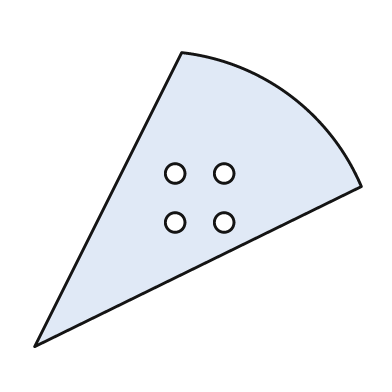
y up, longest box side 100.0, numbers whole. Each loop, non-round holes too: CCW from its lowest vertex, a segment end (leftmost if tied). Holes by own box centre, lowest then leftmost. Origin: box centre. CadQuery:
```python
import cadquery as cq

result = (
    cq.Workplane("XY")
    .moveTo(-50.0, -45.0)
    .lineTo(50.0, 4.0)
    .threePointArc((28.0, 32.0), (-5.0, 45.0))
    .close()
    .moveTo(-7.0, -7.0)
    .circle(3.0)
    .moveTo(8.0, -7.0)
    .circle(3.0)
    .moveTo(-7.0, 8.0)
    .circle(3.0)
    .moveTo(8.0, 8.0)
    .circle(3.0)
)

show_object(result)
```